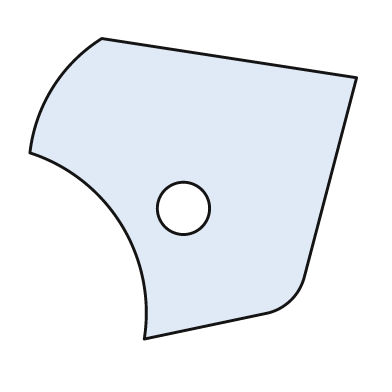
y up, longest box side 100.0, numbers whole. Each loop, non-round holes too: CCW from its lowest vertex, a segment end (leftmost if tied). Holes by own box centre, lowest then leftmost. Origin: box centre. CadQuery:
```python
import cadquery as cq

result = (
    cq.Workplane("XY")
    .moveTo(-15.0, -46.0)
    .lineTo(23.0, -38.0)
    .threePointArc((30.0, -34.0), (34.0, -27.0))
    .lineTo(50.0, 34.0)
    .lineTo(-28.0, 46.0)
    .threePointArc((-43.0, 31.0), (-50.0, 11.0))
    .threePointArc((-22.0, -11.0), (-15.0, -46.0))
    .close()
    .moveTo(-3.0, -6.0)
    .circle(8.0)
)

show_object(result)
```